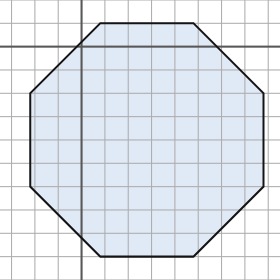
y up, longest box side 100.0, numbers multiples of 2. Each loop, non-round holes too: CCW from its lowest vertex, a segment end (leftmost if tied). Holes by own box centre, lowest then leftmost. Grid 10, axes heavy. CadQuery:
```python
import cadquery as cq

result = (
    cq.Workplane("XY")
    .moveTo(8.0, -90.0)
    .lineTo(48.0, -90.0)
    .lineTo(78.0, -60.0)
    .lineTo(78.0, -20.0)
    .lineTo(48.0, 10.0)
    .lineTo(8.0, 10.0)
    .lineTo(-22.0, -20.0)
    .lineTo(-22.0, -60.0)
    .close()
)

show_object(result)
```